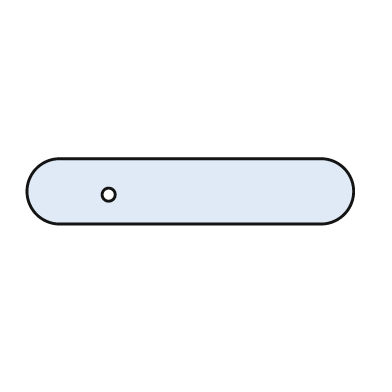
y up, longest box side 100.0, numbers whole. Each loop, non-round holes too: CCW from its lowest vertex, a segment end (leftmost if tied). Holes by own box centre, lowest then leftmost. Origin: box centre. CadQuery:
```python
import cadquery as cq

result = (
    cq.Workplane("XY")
    .moveTo(-40.0, -10.0)
    .lineTo(40.0, -10.0)
    .threePointArc((50.0, 0.0), (40.0, 10.0))
    .lineTo(-40.0, 10.0)
    .threePointArc((-50.0, 0.0), (-40.0, -10.0))
    .close()
    .moveTo(-25.0, -1.0)
    .circle(2.0)
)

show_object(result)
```